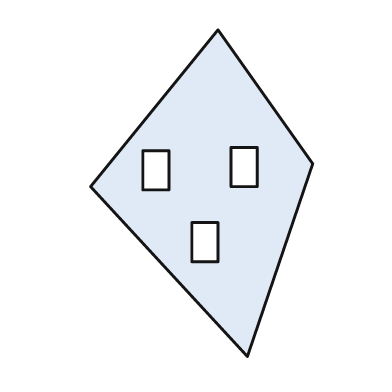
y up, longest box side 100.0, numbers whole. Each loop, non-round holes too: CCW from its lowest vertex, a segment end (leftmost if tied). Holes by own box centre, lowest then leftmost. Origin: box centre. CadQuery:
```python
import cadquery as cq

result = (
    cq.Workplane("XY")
    .moveTo(14.0, -50.0)
    .lineTo(34.0, 9.0)
    .lineTo(5.0, 50.0)
    .lineTo(-34.0, 2.0)
    .close()
    .moveTo(-3.0, -21.0)
    .lineTo(5.0, -21.0)
    .lineTo(5.0, -9.0)
    .lineTo(-3.0, -9.0)
    .close()
    .moveTo(-18.0, 1.0)
    .lineTo(-10.0, 1.0)
    .lineTo(-10.0, 13.0)
    .lineTo(-18.0, 13.0)
    .close()
    .moveTo(9.0, 2.0)
    .lineTo(17.0, 2.0)
    .lineTo(17.0, 14.0)
    .lineTo(9.0, 14.0)
    .close()
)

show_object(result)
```